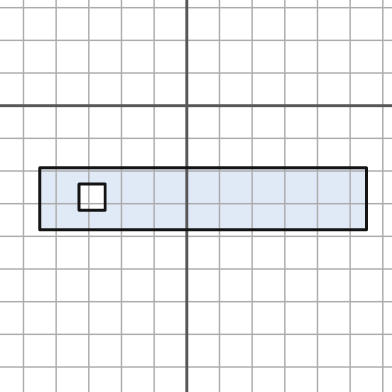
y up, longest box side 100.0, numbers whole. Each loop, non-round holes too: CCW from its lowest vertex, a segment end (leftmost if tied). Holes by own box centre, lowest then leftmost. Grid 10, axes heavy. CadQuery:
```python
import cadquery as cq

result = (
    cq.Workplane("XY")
    .moveTo(-45.0, -38.0)
    .lineTo(55.0, -38.0)
    .lineTo(55.0, -19.0)
    .lineTo(-45.0, -19.0)
    .close()
    .moveTo(-33.0, -32.0)
    .lineTo(-25.0, -32.0)
    .lineTo(-25.0, -24.0)
    .lineTo(-33.0, -24.0)
    .close()
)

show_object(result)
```